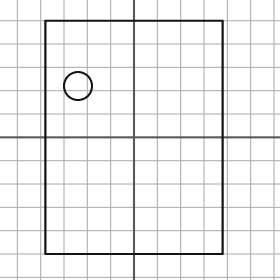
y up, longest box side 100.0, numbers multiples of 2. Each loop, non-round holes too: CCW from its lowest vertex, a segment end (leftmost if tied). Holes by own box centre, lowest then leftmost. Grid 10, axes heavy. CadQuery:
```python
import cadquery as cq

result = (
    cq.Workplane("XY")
    .moveTo(-38.0, -50.0)
    .lineTo(38.0, -50.0)
    .lineTo(38.0, 50.0)
    .lineTo(-38.0, 50.0)
    .close()
    .moveTo(-24.0, 22.0)
    .circle(6.0)
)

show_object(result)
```